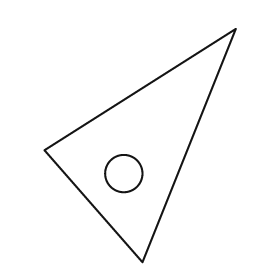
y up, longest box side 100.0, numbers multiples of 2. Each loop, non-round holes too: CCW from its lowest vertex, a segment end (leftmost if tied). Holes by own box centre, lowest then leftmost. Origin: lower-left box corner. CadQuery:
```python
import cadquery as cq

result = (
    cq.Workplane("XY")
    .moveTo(42.0, 0.0)
    .lineTo(82.0, 100.0)
    .lineTo(0.0, 48.0)
    .close()
    .moveTo(34.0, 38.0)
    .circle(8.0)
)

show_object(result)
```